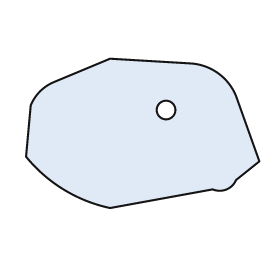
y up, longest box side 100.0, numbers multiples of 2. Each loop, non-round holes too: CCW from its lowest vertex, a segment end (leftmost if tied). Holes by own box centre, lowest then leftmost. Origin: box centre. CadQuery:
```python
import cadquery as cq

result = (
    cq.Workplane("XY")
    .moveTo(-14.0, -32.0)
    .lineTo(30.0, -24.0)
    .threePointArc((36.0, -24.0), (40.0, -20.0))
    .lineTo(50.0, -12.0)
    .lineTo(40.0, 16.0)
    .threePointArc((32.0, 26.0), (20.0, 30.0))
    .lineTo(-14.0, 32.0)
    .lineTo(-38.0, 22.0)
    .threePointArc((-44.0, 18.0), (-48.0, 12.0))
    .lineTo(-50.0, -10.0)
    .threePointArc((-34.0, -24.0), (-14.0, -32.0))
    .close()
    .moveTo(10.0, 10.0)
    .circle(4.0)
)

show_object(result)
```